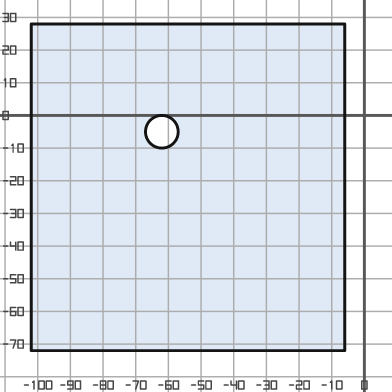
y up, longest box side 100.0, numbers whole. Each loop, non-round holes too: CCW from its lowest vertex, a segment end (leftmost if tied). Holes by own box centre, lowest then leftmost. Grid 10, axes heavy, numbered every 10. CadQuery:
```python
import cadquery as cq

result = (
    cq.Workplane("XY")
    .moveTo(-102.0, -72.0)
    .lineTo(-6.0, -72.0)
    .lineTo(-6.0, 28.0)
    .lineTo(-102.0, 28.0)
    .close()
    .moveTo(-62.0, -5.0)
    .circle(5.0)
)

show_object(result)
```